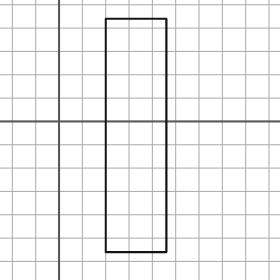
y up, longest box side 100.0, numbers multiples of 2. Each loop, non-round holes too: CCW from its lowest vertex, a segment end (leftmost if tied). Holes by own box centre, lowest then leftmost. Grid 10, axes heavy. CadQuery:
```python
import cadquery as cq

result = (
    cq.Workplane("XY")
    .moveTo(20.0, -56.0)
    .lineTo(46.0, -56.0)
    .lineTo(46.0, 44.0)
    .lineTo(20.0, 44.0)
    .close()
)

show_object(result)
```